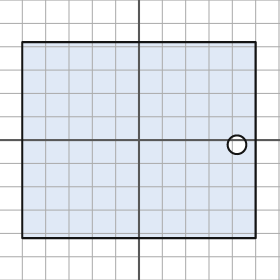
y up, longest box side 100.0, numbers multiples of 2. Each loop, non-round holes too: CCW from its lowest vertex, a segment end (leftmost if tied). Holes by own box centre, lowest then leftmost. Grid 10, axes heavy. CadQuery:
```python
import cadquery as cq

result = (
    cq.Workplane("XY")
    .moveTo(-50.0, -42.0)
    .lineTo(50.0, -42.0)
    .lineTo(50.0, 42.0)
    .lineTo(-50.0, 42.0)
    .close()
    .moveTo(42.0, -2.0)
    .circle(4.0)
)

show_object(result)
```